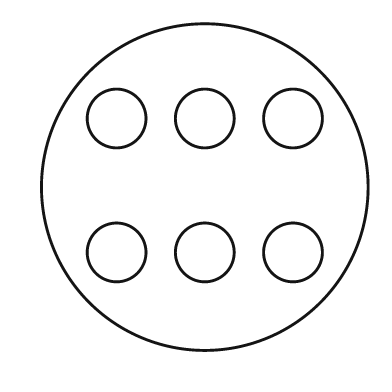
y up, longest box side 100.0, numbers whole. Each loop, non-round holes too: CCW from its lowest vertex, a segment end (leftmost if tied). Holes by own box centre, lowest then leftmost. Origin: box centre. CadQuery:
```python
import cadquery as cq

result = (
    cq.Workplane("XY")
    .moveTo(0.0, 0.0)
    .circle(50.0)
    .moveTo(-27.0, -20.0)
    .circle(9.0)
    .moveTo(0.0, -20.0)
    .circle(9.0)
    .moveTo(27.0, -20.0)
    .circle(9.0)
    .moveTo(-27.0, 21.0)
    .circle(9.0)
    .moveTo(0.0, 21.0)
    .circle(9.0)
    .moveTo(27.0, 21.0)
    .circle(9.0)
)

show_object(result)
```